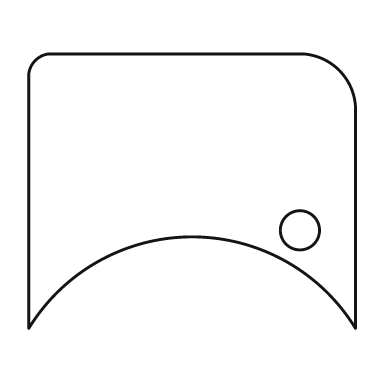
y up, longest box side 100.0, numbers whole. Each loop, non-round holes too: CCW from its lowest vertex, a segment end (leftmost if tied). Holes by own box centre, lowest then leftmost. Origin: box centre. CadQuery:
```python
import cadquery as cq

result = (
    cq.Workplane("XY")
    .moveTo(-50.0, -42.0)
    .threePointArc((0.0, -14.0), (50.0, -42.0))
    .lineTo(50.0, 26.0)
    .threePointArc((45.0, 37.0), (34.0, 42.0))
    .lineTo(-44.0, 42.0)
    .threePointArc((-48.0, 40.0), (-50.0, 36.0))
    .close()
    .moveTo(33.0, -12.0)
    .circle(6.0)
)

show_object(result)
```